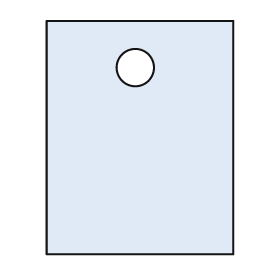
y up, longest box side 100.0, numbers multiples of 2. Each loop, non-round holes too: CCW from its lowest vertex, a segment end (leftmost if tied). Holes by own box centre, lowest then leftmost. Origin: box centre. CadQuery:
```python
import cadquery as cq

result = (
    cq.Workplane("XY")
    .moveTo(-40.0, -50.0)
    .lineTo(40.0, -50.0)
    .lineTo(40.0, 50.0)
    .lineTo(-40.0, 50.0)
    .close()
    .moveTo(-2.0, 30.0)
    .circle(8.0)
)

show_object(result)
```